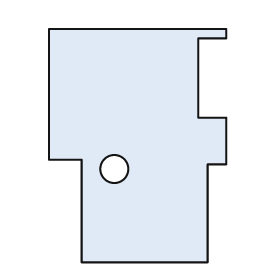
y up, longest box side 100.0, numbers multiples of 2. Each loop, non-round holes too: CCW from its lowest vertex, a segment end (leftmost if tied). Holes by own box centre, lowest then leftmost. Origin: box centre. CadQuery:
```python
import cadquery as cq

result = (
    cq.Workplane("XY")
    .moveTo(-24.0, -50.0)
    .lineTo(30.0, -50.0)
    .lineTo(30.0, -8.0)
    .lineTo(38.0, -8.0)
    .lineTo(38.0, 12.0)
    .lineTo(26.0, 12.0)
    .lineTo(26.0, 46.0)
    .lineTo(38.0, 46.0)
    .lineTo(38.0, 50.0)
    .lineTo(-38.0, 50.0)
    .lineTo(-38.0, -6.0)
    .lineTo(-24.0, -6.0)
    .close()
    .moveTo(-10.0, -10.0)
    .circle(6.0)
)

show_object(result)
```